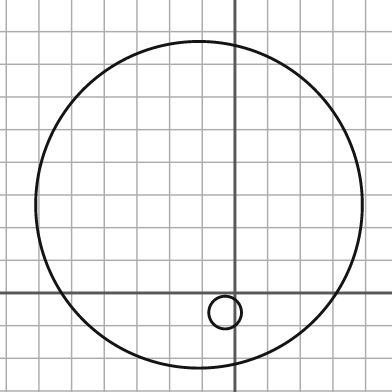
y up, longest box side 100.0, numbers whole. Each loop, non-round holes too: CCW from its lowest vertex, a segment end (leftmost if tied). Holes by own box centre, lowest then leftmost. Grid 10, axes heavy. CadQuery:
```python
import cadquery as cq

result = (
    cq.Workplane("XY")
    .moveTo(-11.0, 27.0)
    .circle(50.0)
    .moveTo(-3.0, -6.0)
    .circle(5.0)
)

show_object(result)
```